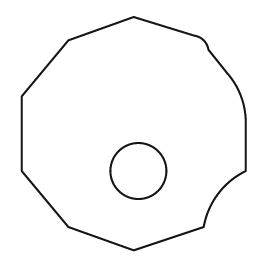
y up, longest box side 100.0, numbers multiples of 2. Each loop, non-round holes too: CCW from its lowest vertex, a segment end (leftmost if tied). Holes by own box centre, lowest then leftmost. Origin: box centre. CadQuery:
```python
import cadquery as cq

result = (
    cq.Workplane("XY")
    .moveTo(0.0, -50.0)
    .lineTo(30.0, -40.0)
    .threePointArc((36.0, -26.0), (48.0, -16.0))
    .lineTo(48.0, 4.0)
    .threePointArc((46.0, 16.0), (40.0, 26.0))
    .lineTo(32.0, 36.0)
    .threePointArc((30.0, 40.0), (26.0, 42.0))
    .lineTo(0.0, 50.0)
    .lineTo(-28.0, 40.0)
    .lineTo(-48.0, 16.0)
    .lineTo(-48.0, -16.0)
    .lineTo(-28.0, -40.0)
    .close()
    .moveTo(2.0, -16.0)
    .circle(12.0)
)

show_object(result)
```